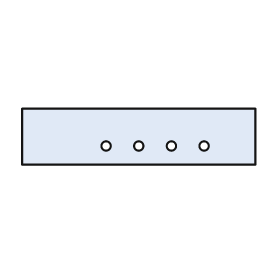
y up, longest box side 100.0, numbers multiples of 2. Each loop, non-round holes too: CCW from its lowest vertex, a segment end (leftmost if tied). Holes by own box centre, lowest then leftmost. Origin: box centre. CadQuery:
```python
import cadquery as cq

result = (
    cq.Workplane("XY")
    .moveTo(-50.0, -12.0)
    .lineTo(50.0, -12.0)
    .lineTo(50.0, 12.0)
    .lineTo(-50.0, 12.0)
    .close()
    .moveTo(-14.0, -4.0)
    .circle(2.0)
    .moveTo(0.0, -4.0)
    .circle(2.0)
    .moveTo(14.0, -4.0)
    .circle(2.0)
    .moveTo(28.0, -4.0)
    .circle(2.0)
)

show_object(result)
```